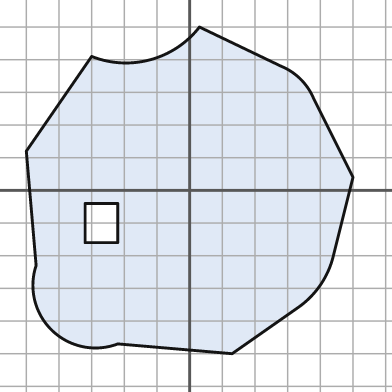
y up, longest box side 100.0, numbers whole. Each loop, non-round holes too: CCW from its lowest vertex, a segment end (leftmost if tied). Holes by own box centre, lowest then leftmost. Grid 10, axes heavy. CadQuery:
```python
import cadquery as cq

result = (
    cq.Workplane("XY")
    .moveTo(13.0, -50.0)
    .lineTo(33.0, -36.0)
    .threePointArc((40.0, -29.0), (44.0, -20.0))
    .lineTo(50.0, 4.0)
    .lineTo(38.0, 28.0)
    .threePointArc((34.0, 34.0), (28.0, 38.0))
    .lineTo(3.0, 50.0)
    .threePointArc((-12.0, 40.0), (-30.0, 41.0))
    .lineTo(-50.0, 12.0)
    .lineTo(-47.0, -23.0)
    .threePointArc((-42.0, -43.0), (-22.0, -47.0))
    .close()
    .moveTo(-32.0, -16.0)
    .lineTo(-22.0, -16.0)
    .lineTo(-22.0, -4.0)
    .lineTo(-32.0, -4.0)
    .close()
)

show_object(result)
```